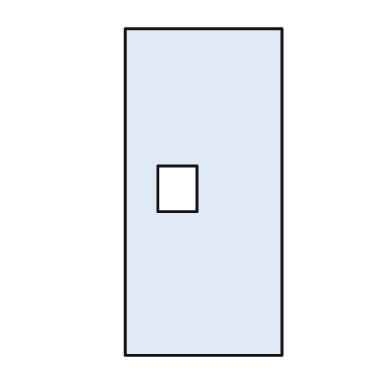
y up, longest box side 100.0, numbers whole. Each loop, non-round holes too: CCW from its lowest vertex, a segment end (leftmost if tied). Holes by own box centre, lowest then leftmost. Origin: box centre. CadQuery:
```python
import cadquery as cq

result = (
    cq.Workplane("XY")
    .moveTo(-24.0, -50.0)
    .lineTo(24.0, -50.0)
    .lineTo(24.0, 50.0)
    .lineTo(-24.0, 50.0)
    .close()
    .moveTo(-14.0, -6.0)
    .lineTo(-2.0, -6.0)
    .lineTo(-2.0, 8.0)
    .lineTo(-14.0, 8.0)
    .close()
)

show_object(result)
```